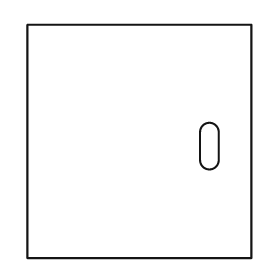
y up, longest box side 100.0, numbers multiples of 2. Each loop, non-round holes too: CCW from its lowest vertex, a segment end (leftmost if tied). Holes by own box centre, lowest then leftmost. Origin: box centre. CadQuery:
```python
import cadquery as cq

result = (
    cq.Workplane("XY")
    .moveTo(-48.0, -50.0)
    .lineTo(48.0, -50.0)
    .lineTo(48.0, 50.0)
    .lineTo(-48.0, 50.0)
    .close()
    .moveTo(26.0, -8.0)
    .threePointArc((30.0, -12.0), (34.0, -8.0))
    .lineTo(34.0, 4.0)
    .threePointArc((30.0, 8.0), (26.0, 4.0))
    .close()
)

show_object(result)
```